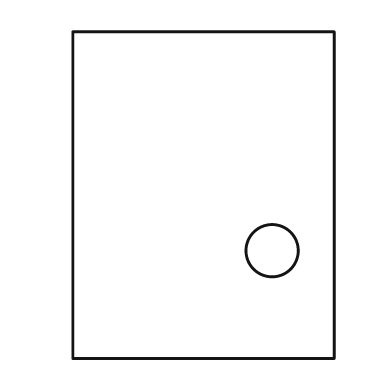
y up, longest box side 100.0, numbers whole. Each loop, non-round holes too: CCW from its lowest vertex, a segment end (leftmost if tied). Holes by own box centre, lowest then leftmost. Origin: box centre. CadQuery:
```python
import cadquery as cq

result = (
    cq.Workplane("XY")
    .moveTo(-40.0, -50.0)
    .lineTo(40.0, -50.0)
    .lineTo(40.0, 50.0)
    .lineTo(-40.0, 50.0)
    .close()
    .moveTo(21.0, -17.0)
    .circle(8.0)
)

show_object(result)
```